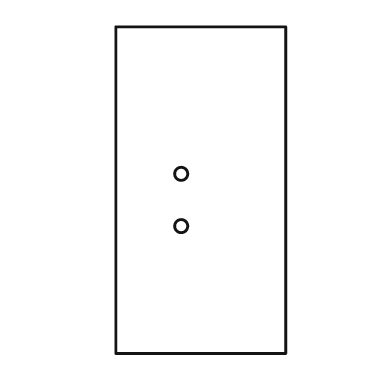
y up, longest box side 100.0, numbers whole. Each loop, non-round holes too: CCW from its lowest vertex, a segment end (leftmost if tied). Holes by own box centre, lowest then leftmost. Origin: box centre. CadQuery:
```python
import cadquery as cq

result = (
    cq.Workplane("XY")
    .moveTo(-26.0, -50.0)
    .lineTo(26.0, -50.0)
    .lineTo(26.0, 50.0)
    .lineTo(-26.0, 50.0)
    .close()
    .moveTo(-6.0, -11.0)
    .circle(2.0)
    .moveTo(-6.0, 5.0)
    .circle(2.0)
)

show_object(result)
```